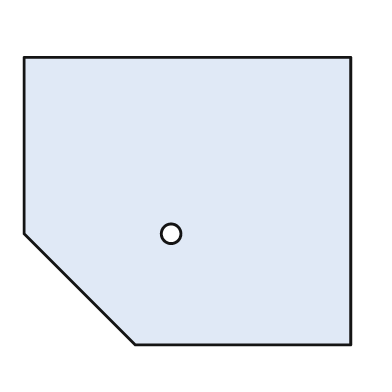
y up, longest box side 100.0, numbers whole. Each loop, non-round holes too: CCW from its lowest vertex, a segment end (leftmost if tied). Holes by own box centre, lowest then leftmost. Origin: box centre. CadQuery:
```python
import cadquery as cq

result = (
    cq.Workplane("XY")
    .moveTo(-16.0, -44.0)
    .lineTo(50.0, -44.0)
    .lineTo(50.0, 44.0)
    .lineTo(-50.0, 44.0)
    .lineTo(-50.0, -10.0)
    .close()
    .moveTo(-5.0, -10.0)
    .circle(3.0)
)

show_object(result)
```